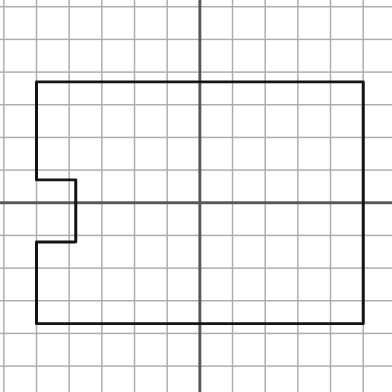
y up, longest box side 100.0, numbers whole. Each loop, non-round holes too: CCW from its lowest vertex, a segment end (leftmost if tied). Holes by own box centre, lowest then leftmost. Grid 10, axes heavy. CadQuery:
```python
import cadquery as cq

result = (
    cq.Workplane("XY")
    .moveTo(-50.0, -37.0)
    .lineTo(50.0, -37.0)
    .lineTo(50.0, 37.0)
    .lineTo(-50.0, 37.0)
    .lineTo(-50.0, 7.0)
    .lineTo(-38.0, 7.0)
    .lineTo(-38.0, -12.0)
    .lineTo(-50.0, -12.0)
    .close()
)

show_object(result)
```